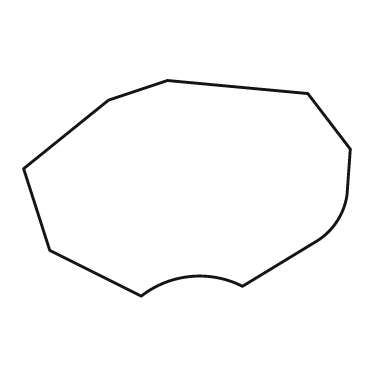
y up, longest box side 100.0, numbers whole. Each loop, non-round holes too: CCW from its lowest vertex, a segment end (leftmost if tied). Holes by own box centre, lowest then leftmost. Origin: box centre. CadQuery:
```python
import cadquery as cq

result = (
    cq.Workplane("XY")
    .moveTo(-14.0, -33.0)
    .threePointArc((1.0, -27.0), (17.0, -30.0))
    .lineTo(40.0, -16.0)
    .threePointArc((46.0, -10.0), (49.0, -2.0))
    .lineTo(50.0, 12.0)
    .lineTo(37.0, 29.0)
    .lineTo(-6.0, 33.0)
    .lineTo(-24.0, 27.0)
    .lineTo(-50.0, 6.0)
    .lineTo(-42.0, -19.0)
    .close()
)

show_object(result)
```